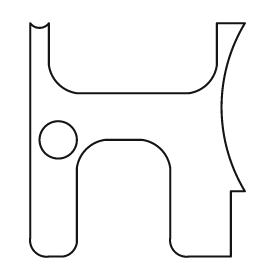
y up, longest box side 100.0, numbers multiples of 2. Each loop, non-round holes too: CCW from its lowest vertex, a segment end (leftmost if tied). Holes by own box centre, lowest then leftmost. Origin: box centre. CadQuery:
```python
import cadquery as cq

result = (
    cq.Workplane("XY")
    .moveTo(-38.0, -50.0)
    .lineTo(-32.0, -50.0)
    .threePointArc((-28.0, -48.0), (-26.0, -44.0))
    .lineTo(-26.0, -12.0)
    .threePointArc((-22.0, -4.0), (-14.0, 0.0))
    .lineTo(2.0, 0.0)
    .threePointArc((10.0, -4.0), (14.0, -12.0))
    .lineTo(14.0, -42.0)
    .threePointArc((16.0, -48.0), (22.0, -50.0))
    .lineTo(40.0, -50.0)
    .lineTo(40.0, -22.0)
    .lineTo(46.0, -22.0)
    .threePointArc((36.0, 14.0), (46.0, 50.0))
    .lineTo(34.0, 50.0)
    .lineTo(34.0, 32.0)
    .threePointArc((30.0, 24.0), (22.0, 20.0))
    .lineTo(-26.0, 20.0)
    .threePointArc((-34.0, 24.0), (-38.0, 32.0))
    .lineTo(-38.0, 50.0)
    .threePointArc((-42.0, 48.0), (-46.0, 50.0))
    .lineTo(-46.0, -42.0)
    .threePointArc((-44.0, -48.0), (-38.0, -50.0))
    .close()
    .moveTo(-34.0, 0.0)
    .circle(8.0)
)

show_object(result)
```